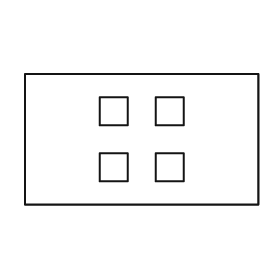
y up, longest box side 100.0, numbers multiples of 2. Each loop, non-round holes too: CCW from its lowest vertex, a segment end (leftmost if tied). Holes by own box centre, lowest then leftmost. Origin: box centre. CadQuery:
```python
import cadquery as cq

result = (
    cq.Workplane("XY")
    .moveTo(-50.0, -28.0)
    .lineTo(50.0, -28.0)
    .lineTo(50.0, 28.0)
    .lineTo(-50.0, 28.0)
    .close()
    .moveTo(-18.0, -18.0)
    .lineTo(-6.0, -18.0)
    .lineTo(-6.0, -6.0)
    .lineTo(-18.0, -6.0)
    .close()
    .moveTo(6.0, -18.0)
    .lineTo(18.0, -18.0)
    .lineTo(18.0, -6.0)
    .lineTo(6.0, -6.0)
    .close()
    .moveTo(-18.0, 6.0)
    .lineTo(-6.0, 6.0)
    .lineTo(-6.0, 18.0)
    .lineTo(-18.0, 18.0)
    .close()
    .moveTo(6.0, 6.0)
    .lineTo(18.0, 6.0)
    .lineTo(18.0, 18.0)
    .lineTo(6.0, 18.0)
    .close()
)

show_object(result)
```